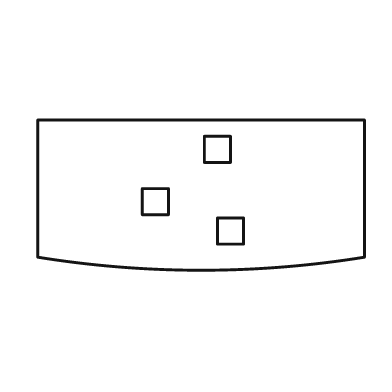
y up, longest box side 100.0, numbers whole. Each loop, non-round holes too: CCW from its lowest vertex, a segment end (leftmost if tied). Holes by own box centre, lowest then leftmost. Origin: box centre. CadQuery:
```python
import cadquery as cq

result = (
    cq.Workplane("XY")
    .moveTo(-50.0, -19.0)
    .threePointArc((0.0, -23.0), (50.0, -19.0))
    .lineTo(50.0, 23.0)
    .lineTo(-50.0, 23.0)
    .close()
    .moveTo(5.0, -15.0)
    .lineTo(13.0, -15.0)
    .lineTo(13.0, -7.0)
    .lineTo(5.0, -7.0)
    .close()
    .moveTo(-18.0, -6.0)
    .lineTo(-10.0, -6.0)
    .lineTo(-10.0, 2.0)
    .lineTo(-18.0, 2.0)
    .close()
    .moveTo(1.0, 10.0)
    .lineTo(9.0, 10.0)
    .lineTo(9.0, 18.0)
    .lineTo(1.0, 18.0)
    .close()
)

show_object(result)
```